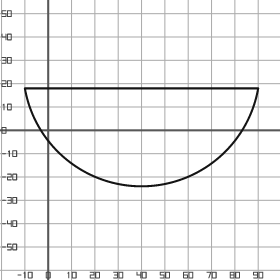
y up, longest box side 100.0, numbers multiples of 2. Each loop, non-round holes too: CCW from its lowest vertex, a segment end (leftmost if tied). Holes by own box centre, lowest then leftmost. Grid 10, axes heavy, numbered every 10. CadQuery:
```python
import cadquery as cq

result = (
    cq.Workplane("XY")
    .moveTo(-10.0, 18.0)
    .threePointArc((40.0, -24.0), (90.0, 18.0))
    .close()
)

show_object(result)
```